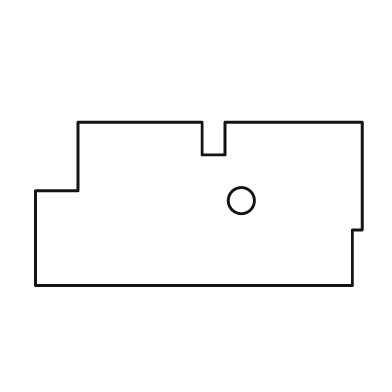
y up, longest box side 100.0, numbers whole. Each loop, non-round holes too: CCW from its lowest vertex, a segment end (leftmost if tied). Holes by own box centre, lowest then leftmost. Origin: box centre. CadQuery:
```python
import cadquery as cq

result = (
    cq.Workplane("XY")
    .moveTo(-50.0, -25.0)
    .lineTo(47.0, -25.0)
    .lineTo(47.0, -8.0)
    .lineTo(50.0, -8.0)
    .lineTo(50.0, 25.0)
    .lineTo(8.0, 25.0)
    .lineTo(8.0, 15.0)
    .lineTo(1.0, 15.0)
    .lineTo(1.0, 25.0)
    .lineTo(-37.0, 25.0)
    .lineTo(-37.0, 4.0)
    .lineTo(-50.0, 4.0)
    .close()
    .moveTo(13.0, 1.0)
    .circle(4.0)
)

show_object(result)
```